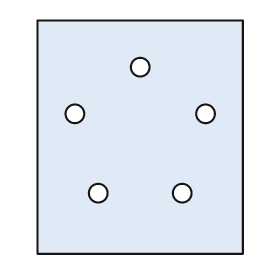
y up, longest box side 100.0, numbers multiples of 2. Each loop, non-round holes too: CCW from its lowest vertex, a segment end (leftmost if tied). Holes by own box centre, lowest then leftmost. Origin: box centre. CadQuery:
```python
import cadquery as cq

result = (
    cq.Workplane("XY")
    .moveTo(-44.0, -50.0)
    .lineTo(44.0, -50.0)
    .lineTo(44.0, 50.0)
    .lineTo(-44.0, 50.0)
    .close()
    .moveTo(-18.0, -24.0)
    .circle(4.0)
    .moveTo(18.0, -24.0)
    .circle(4.0)
    .moveTo(-28.0, 10.0)
    .circle(4.0)
    .moveTo(28.0, 10.0)
    .circle(4.0)
    .moveTo(0.0, 30.0)
    .circle(4.0)
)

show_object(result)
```